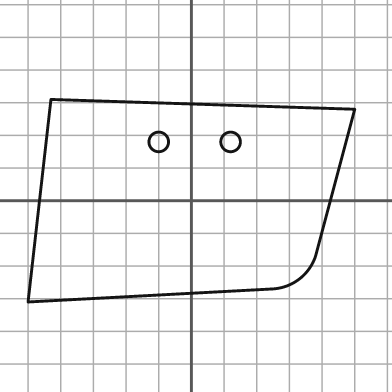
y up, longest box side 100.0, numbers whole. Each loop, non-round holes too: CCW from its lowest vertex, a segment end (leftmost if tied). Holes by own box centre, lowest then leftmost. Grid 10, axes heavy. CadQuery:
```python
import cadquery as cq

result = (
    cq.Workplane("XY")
    .moveTo(-50.0, -31.0)
    .lineTo(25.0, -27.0)
    .threePointArc((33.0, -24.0), (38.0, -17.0))
    .lineTo(50.0, 28.0)
    .lineTo(-43.0, 31.0)
    .close()
    .moveTo(-10.0, 18.0)
    .circle(3.0)
    .moveTo(12.0, 18.0)
    .circle(3.0)
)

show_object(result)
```